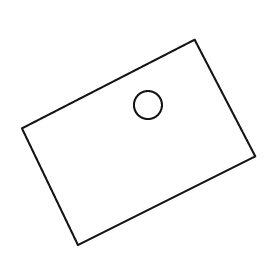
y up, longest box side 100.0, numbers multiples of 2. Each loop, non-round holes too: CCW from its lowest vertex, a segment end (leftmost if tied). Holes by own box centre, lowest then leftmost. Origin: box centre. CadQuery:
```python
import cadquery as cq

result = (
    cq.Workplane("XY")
    .moveTo(-26.0, -44.0)
    .lineTo(50.0, -6.0)
    .lineTo(24.0, 44.0)
    .lineTo(-50.0, 6.0)
    .close()
    .moveTo(4.0, 16.0)
    .circle(6.0)
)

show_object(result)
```